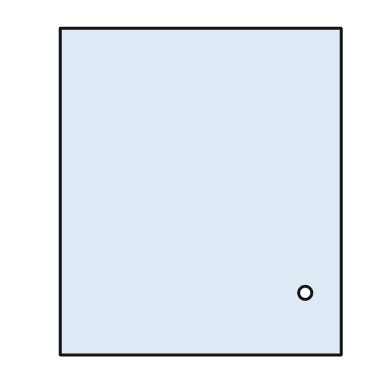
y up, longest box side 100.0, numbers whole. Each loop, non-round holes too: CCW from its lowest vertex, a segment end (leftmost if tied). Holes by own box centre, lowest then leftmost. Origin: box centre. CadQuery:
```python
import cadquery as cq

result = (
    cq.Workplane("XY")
    .moveTo(-43.0, -50.0)
    .lineTo(43.0, -50.0)
    .lineTo(43.0, 50.0)
    .lineTo(-43.0, 50.0)
    .close()
    .moveTo(32.0, -31.0)
    .circle(2.0)
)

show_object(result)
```